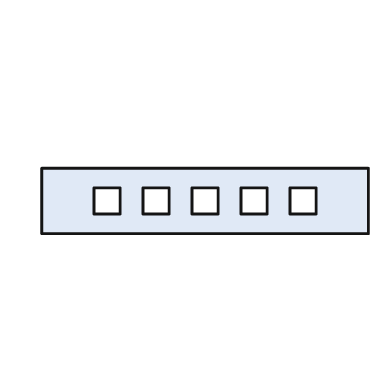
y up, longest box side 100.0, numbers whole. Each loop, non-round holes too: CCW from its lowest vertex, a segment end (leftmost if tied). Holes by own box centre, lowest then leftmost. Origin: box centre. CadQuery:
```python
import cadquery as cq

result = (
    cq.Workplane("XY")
    .moveTo(-50.0, -10.0)
    .lineTo(50.0, -10.0)
    .lineTo(50.0, 10.0)
    .lineTo(-50.0, 10.0)
    .close()
    .moveTo(-34.0, -4.0)
    .lineTo(-26.0, -4.0)
    .lineTo(-26.0, 4.0)
    .lineTo(-34.0, 4.0)
    .close()
    .moveTo(-19.0, -4.0)
    .lineTo(-11.0, -4.0)
    .lineTo(-11.0, 4.0)
    .lineTo(-19.0, 4.0)
    .close()
    .moveTo(-4.0, -4.0)
    .lineTo(4.0, -4.0)
    .lineTo(4.0, 4.0)
    .lineTo(-4.0, 4.0)
    .close()
    .moveTo(11.0, -4.0)
    .lineTo(19.0, -4.0)
    .lineTo(19.0, 4.0)
    .lineTo(11.0, 4.0)
    .close()
    .moveTo(26.0, -4.0)
    .lineTo(34.0, -4.0)
    .lineTo(34.0, 4.0)
    .lineTo(26.0, 4.0)
    .close()
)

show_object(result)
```